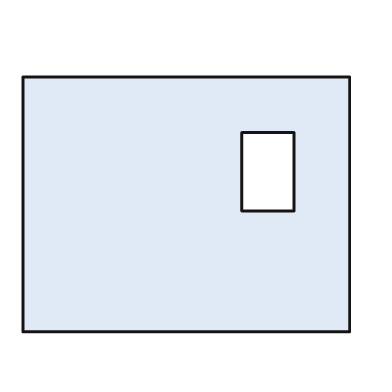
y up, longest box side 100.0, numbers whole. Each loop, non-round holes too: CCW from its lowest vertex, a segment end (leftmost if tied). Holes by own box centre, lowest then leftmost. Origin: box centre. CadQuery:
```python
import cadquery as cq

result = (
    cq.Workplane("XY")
    .moveTo(-50.0, -39.0)
    .lineTo(50.0, -39.0)
    .lineTo(50.0, 39.0)
    .lineTo(-50.0, 39.0)
    .close()
    .moveTo(17.0, -2.0)
    .lineTo(33.0, -2.0)
    .lineTo(33.0, 22.0)
    .lineTo(17.0, 22.0)
    .close()
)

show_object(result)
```